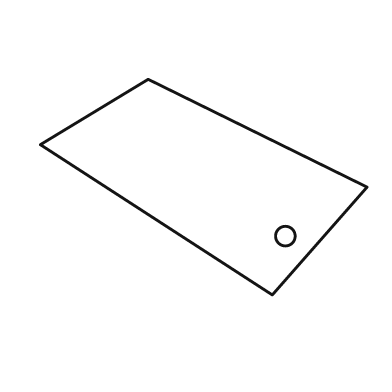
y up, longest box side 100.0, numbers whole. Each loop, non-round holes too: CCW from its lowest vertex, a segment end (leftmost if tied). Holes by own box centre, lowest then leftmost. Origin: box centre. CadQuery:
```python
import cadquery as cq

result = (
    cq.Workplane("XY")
    .moveTo(21.0, -33.0)
    .lineTo(50.0, 0.0)
    .lineTo(-17.0, 33.0)
    .lineTo(-50.0, 13.0)
    .close()
    .moveTo(25.0, -15.0)
    .circle(3.0)
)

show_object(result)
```